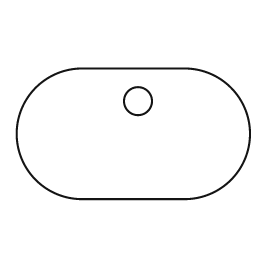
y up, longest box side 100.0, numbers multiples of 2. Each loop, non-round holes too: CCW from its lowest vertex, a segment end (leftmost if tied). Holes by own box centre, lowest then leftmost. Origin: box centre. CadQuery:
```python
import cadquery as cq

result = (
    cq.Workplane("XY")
    .moveTo(-22.0, -28.0)
    .lineTo(22.0, -28.0)
    .threePointArc((50.0, 0.0), (22.0, 28.0))
    .lineTo(-22.0, 28.0)
    .threePointArc((-50.0, 0.0), (-22.0, -28.0))
    .close()
    .moveTo(2.0, 14.0)
    .circle(6.0)
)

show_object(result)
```